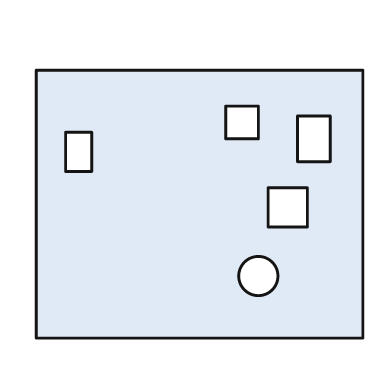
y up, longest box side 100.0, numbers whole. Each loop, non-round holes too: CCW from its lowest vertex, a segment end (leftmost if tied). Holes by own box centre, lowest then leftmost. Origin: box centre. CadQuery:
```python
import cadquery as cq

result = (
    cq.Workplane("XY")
    .moveTo(-50.0, -41.0)
    .lineTo(50.0, -41.0)
    .lineTo(50.0, 41.0)
    .lineTo(-50.0, 41.0)
    .close()
    .moveTo(18.0, -22.0)
    .circle(6.0)
    .moveTo(21.0, -7.0)
    .lineTo(33.0, -7.0)
    .lineTo(33.0, 5.0)
    .lineTo(21.0, 5.0)
    .close()
    .moveTo(-41.0, 10.0)
    .lineTo(-33.0, 10.0)
    .lineTo(-33.0, 22.0)
    .lineTo(-41.0, 22.0)
    .close()
    .moveTo(30.0, 13.0)
    .lineTo(40.0, 13.0)
    .lineTo(40.0, 27.0)
    .lineTo(30.0, 27.0)
    .close()
    .moveTo(8.0, 20.0)
    .lineTo(18.0, 20.0)
    .lineTo(18.0, 30.0)
    .lineTo(8.0, 30.0)
    .close()
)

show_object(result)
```